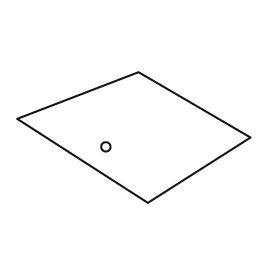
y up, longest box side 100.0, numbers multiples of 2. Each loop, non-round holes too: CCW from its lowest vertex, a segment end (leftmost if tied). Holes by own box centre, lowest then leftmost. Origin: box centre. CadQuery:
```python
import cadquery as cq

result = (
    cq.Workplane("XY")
    .moveTo(6.0, -28.0)
    .lineTo(50.0, 0.0)
    .lineTo(2.0, 28.0)
    .lineTo(-50.0, 8.0)
    .close()
    .moveTo(-12.0, -4.0)
    .circle(2.0)
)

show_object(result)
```